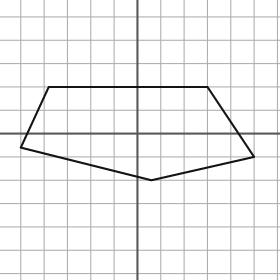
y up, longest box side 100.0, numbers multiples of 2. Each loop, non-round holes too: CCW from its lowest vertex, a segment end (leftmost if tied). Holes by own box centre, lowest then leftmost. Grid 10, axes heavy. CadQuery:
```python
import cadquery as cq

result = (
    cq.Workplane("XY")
    .moveTo(6.0, -20.0)
    .lineTo(50.0, -10.0)
    .lineTo(30.0, 20.0)
    .lineTo(-38.0, 20.0)
    .lineTo(-50.0, -6.0)
    .close()
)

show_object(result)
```